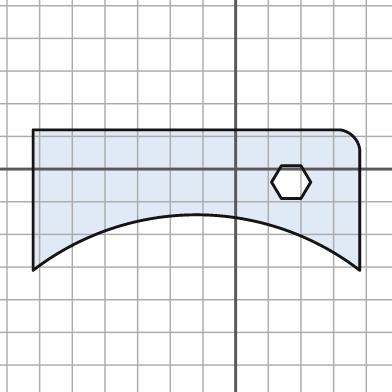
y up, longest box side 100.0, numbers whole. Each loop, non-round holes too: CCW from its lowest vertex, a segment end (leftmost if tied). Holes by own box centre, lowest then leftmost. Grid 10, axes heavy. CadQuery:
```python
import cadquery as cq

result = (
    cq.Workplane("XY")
    .moveTo(-62.0, -31.0)
    .threePointArc((-12.0, -14.0), (38.0, -31.0))
    .lineTo(38.0, 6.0)
    .threePointArc((36.0, 10.0), (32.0, 12.0))
    .lineTo(-62.0, 12.0)
    .close()
    .moveTo(14.0, -9.0)
    .lineTo(20.0, -9.0)
    .lineTo(23.0, -4.0)
    .lineTo(20.0, 1.0)
    .lineTo(14.0, 1.0)
    .lineTo(11.0, -4.0)
    .close()
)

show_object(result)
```